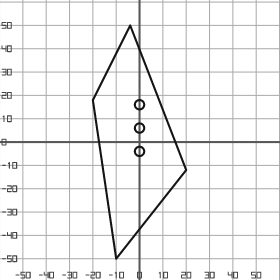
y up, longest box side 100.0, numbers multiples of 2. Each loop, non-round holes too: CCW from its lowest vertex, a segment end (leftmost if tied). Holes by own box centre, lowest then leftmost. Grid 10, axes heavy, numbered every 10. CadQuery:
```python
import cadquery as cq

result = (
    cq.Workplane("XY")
    .moveTo(-10.0, -50.0)
    .lineTo(20.0, -12.0)
    .lineTo(-4.0, 50.0)
    .lineTo(-20.0, 18.0)
    .close()
    .moveTo(0.0, -4.0)
    .circle(2.0)
    .moveTo(0.0, 6.0)
    .circle(2.0)
    .moveTo(0.0, 16.0)
    .circle(2.0)
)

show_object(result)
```